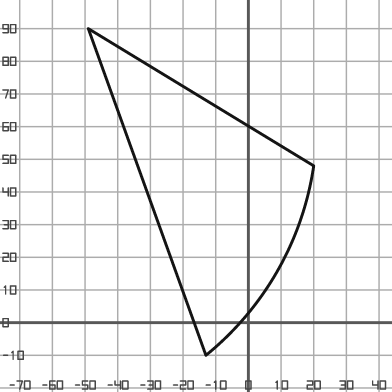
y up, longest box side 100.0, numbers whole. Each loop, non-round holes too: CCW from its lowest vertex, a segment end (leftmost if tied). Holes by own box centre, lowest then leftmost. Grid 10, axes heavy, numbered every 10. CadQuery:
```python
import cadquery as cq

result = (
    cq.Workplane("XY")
    .moveTo(-13.0, -10.0)
    .threePointArc((9.0, 16.0), (20.0, 48.0))
    .lineTo(-49.0, 90.0)
    .close()
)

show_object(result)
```